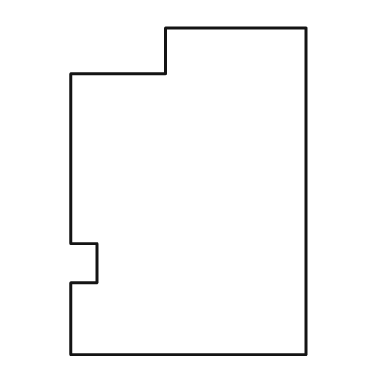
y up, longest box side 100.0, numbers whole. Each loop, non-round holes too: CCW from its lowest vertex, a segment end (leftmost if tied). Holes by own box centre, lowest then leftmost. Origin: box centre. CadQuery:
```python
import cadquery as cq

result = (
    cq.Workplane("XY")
    .moveTo(-36.0, -50.0)
    .lineTo(36.0, -50.0)
    .lineTo(36.0, 50.0)
    .lineTo(-7.0, 50.0)
    .lineTo(-7.0, 36.0)
    .lineTo(-36.0, 36.0)
    .lineTo(-36.0, -16.0)
    .lineTo(-28.0, -16.0)
    .lineTo(-28.0, -28.0)
    .lineTo(-36.0, -28.0)
    .close()
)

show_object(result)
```